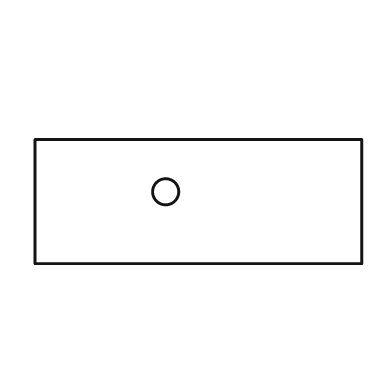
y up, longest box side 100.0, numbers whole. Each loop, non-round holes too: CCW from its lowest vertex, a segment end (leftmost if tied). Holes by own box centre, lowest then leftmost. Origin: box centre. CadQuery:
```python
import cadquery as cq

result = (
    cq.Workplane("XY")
    .moveTo(-50.0, -19.0)
    .lineTo(50.0, -19.0)
    .lineTo(50.0, 19.0)
    .lineTo(-50.0, 19.0)
    .close()
    .moveTo(-10.0, 3.0)
    .circle(4.0)
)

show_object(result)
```